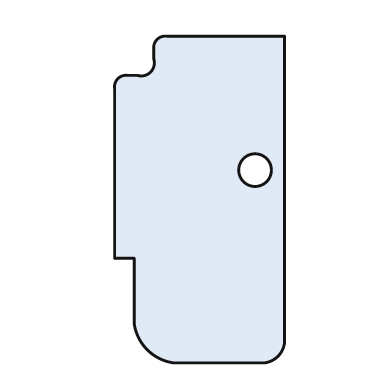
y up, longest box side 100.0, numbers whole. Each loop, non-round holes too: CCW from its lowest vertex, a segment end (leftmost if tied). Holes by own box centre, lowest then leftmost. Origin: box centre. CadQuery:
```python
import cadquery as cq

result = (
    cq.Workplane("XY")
    .moveTo(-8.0, -50.0)
    .lineTo(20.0, -50.0)
    .threePointArc((24.0, -48.0), (26.0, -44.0))
    .lineTo(26.0, 50.0)
    .lineTo(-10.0, 50.0)
    .threePointArc((-13.0, 49.0), (-14.0, 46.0))
    .lineTo(-14.0, 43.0)
    .threePointArc((-15.0, 39.0), (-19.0, 38.0))
    .lineTo(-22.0, 38.0)
    .threePointArc((-25.0, 37.0), (-26.0, 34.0))
    .lineTo(-26.0, -18.0)
    .lineTo(-20.0, -18.0)
    .lineTo(-20.0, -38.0)
    .threePointArc((-16.0, -46.0), (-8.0, -50.0))
    .close()
    .moveTo(17.0, 9.0)
    .circle(5.0)
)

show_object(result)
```